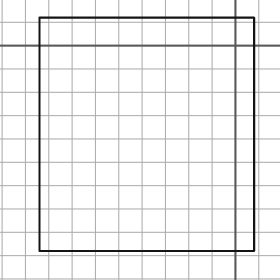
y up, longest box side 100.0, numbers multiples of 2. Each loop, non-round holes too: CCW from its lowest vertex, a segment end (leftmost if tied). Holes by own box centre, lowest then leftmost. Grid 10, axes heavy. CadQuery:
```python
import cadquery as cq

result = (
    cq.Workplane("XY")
    .moveTo(-84.0, -88.0)
    .lineTo(8.0, -88.0)
    .lineTo(8.0, 12.0)
    .lineTo(-84.0, 12.0)
    .close()
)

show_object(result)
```